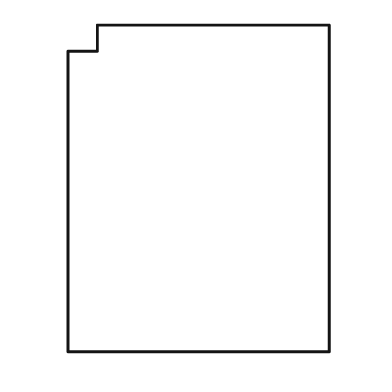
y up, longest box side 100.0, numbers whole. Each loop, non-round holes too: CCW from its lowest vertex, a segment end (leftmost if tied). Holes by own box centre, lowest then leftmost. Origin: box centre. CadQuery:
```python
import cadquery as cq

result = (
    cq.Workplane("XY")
    .moveTo(-40.0, -50.0)
    .lineTo(40.0, -50.0)
    .lineTo(40.0, 50.0)
    .lineTo(-31.0, 50.0)
    .lineTo(-31.0, 42.0)
    .lineTo(-40.0, 42.0)
    .close()
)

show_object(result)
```